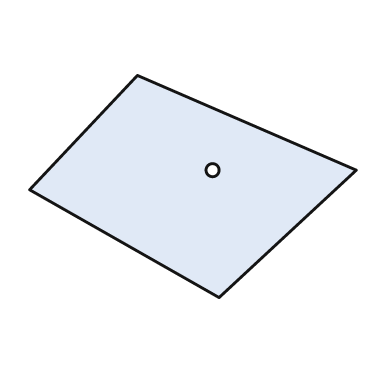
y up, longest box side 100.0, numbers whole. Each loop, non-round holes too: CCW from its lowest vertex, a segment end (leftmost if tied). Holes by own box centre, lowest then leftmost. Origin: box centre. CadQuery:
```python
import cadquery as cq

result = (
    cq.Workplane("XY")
    .moveTo(8.0, -34.0)
    .lineTo(50.0, 5.0)
    .lineTo(-17.0, 34.0)
    .lineTo(-50.0, -1.0)
    .close()
    .moveTo(6.0, 5.0)
    .circle(2.0)
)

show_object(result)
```